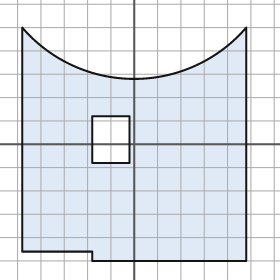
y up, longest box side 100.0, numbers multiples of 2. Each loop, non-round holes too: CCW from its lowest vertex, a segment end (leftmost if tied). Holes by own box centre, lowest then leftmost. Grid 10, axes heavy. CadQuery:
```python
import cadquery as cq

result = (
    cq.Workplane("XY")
    .moveTo(-18.0, -50.0)
    .lineTo(48.0, -50.0)
    .lineTo(48.0, 50.0)
    .threePointArc((0.0, 28.0), (-48.0, 50.0))
    .lineTo(-48.0, -46.0)
    .lineTo(-18.0, -46.0)
    .close()
    .moveTo(-18.0, -8.0)
    .lineTo(-2.0, -8.0)
    .lineTo(-2.0, 12.0)
    .lineTo(-18.0, 12.0)
    .close()
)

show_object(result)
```